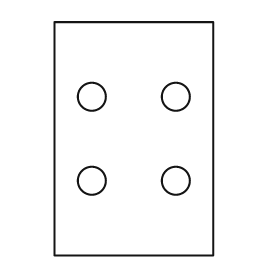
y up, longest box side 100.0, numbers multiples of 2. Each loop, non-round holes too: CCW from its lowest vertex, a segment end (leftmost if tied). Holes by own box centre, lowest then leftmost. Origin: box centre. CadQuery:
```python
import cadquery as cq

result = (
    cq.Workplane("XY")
    .moveTo(-34.0, -50.0)
    .lineTo(34.0, -50.0)
    .lineTo(34.0, 50.0)
    .lineTo(-34.0, 50.0)
    .close()
    .moveTo(-18.0, -18.0)
    .circle(6.0)
    .moveTo(18.0, -18.0)
    .circle(6.0)
    .moveTo(-18.0, 18.0)
    .circle(6.0)
    .moveTo(18.0, 18.0)
    .circle(6.0)
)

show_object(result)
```